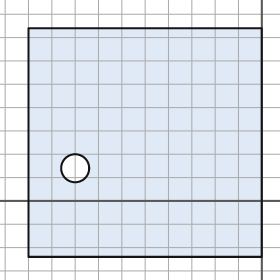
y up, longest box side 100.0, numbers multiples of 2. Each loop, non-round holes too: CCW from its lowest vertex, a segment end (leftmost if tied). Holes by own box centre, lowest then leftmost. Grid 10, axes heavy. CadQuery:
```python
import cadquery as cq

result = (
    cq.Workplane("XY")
    .moveTo(-100.0, -24.0)
    .lineTo(0.0, -24.0)
    .lineTo(0.0, 74.0)
    .lineTo(-100.0, 74.0)
    .close()
    .moveTo(-80.0, 14.0)
    .circle(6.0)
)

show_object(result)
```